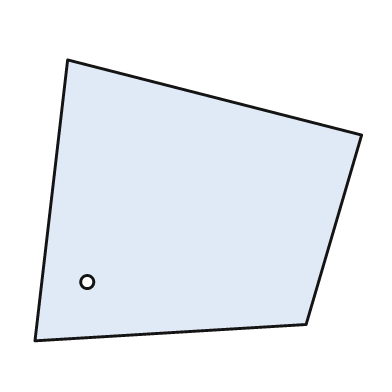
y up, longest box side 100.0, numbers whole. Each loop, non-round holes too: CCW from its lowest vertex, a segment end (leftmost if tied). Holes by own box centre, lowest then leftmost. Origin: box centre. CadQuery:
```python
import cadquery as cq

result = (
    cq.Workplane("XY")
    .moveTo(-50.0, -43.0)
    .lineTo(33.0, -38.0)
    .lineTo(50.0, 20.0)
    .lineTo(-40.0, 43.0)
    .close()
    .moveTo(-34.0, -25.0)
    .circle(2.0)
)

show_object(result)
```